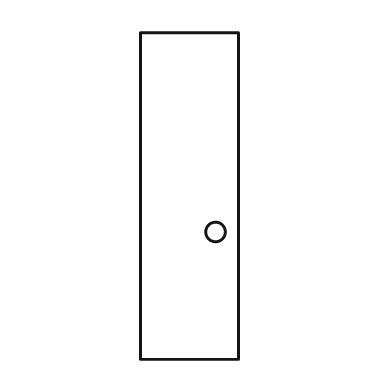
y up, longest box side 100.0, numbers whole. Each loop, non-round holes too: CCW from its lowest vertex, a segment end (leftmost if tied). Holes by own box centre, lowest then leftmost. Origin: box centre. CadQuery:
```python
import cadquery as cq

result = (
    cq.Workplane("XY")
    .moveTo(-15.0, -50.0)
    .lineTo(15.0, -50.0)
    .lineTo(15.0, 50.0)
    .lineTo(-15.0, 50.0)
    .close()
    .moveTo(8.0, -11.0)
    .circle(3.0)
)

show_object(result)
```